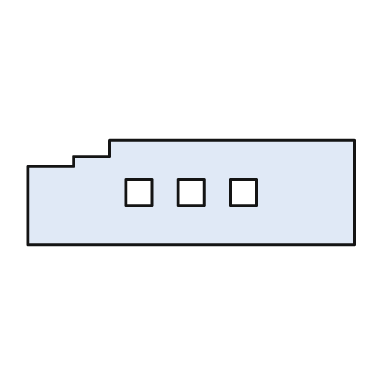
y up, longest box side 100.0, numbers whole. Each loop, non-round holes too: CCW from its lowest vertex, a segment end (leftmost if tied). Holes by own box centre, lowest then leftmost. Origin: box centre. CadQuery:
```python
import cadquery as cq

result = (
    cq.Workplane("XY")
    .moveTo(-50.0, -16.0)
    .lineTo(50.0, -16.0)
    .lineTo(50.0, 16.0)
    .lineTo(-25.0, 16.0)
    .lineTo(-25.0, 11.0)
    .lineTo(-36.0, 11.0)
    .lineTo(-36.0, 8.0)
    .lineTo(-50.0, 8.0)
    .close()
    .moveTo(-20.0, -4.0)
    .lineTo(-12.0, -4.0)
    .lineTo(-12.0, 4.0)
    .lineTo(-20.0, 4.0)
    .close()
    .moveTo(-4.0, -4.0)
    .lineTo(4.0, -4.0)
    .lineTo(4.0, 4.0)
    .lineTo(-4.0, 4.0)
    .close()
    .moveTo(12.0, -4.0)
    .lineTo(20.0, -4.0)
    .lineTo(20.0, 4.0)
    .lineTo(12.0, 4.0)
    .close()
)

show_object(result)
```